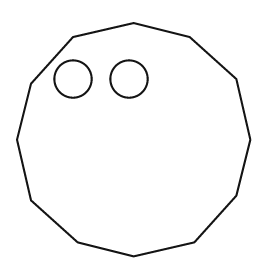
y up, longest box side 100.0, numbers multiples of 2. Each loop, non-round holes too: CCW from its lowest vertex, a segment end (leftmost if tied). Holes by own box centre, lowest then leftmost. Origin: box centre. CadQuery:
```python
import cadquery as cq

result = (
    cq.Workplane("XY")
    .moveTo(0.0, -50.0)
    .lineTo(26.0, -44.0)
    .lineTo(44.0, -24.0)
    .lineTo(50.0, 0.0)
    .lineTo(44.0, 26.0)
    .lineTo(24.0, 44.0)
    .lineTo(0.0, 50.0)
    .lineTo(-26.0, 44.0)
    .lineTo(-44.0, 24.0)
    .lineTo(-50.0, 0.0)
    .lineTo(-44.0, -26.0)
    .lineTo(-24.0, -44.0)
    .close()
    .moveTo(-26.0, 26.0)
    .circle(8.0)
    .moveTo(-2.0, 26.0)
    .circle(8.0)
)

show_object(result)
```